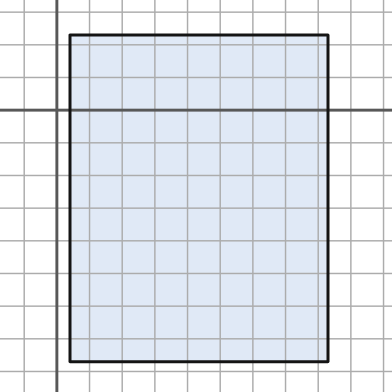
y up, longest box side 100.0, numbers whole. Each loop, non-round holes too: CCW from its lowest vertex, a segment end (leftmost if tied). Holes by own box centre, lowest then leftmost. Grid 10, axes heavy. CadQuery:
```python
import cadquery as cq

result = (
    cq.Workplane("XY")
    .moveTo(4.0, -77.0)
    .lineTo(83.0, -77.0)
    .lineTo(83.0, 23.0)
    .lineTo(4.0, 23.0)
    .close()
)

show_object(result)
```